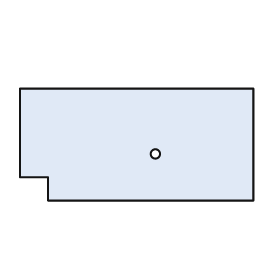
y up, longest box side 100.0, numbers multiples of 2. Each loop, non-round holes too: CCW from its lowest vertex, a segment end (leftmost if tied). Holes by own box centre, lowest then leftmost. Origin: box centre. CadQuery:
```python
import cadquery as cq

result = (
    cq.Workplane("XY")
    .moveTo(-38.0, -24.0)
    .lineTo(50.0, -24.0)
    .lineTo(50.0, 24.0)
    .lineTo(-50.0, 24.0)
    .lineTo(-50.0, -14.0)
    .lineTo(-38.0, -14.0)
    .close()
    .moveTo(8.0, -4.0)
    .circle(2.0)
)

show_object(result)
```